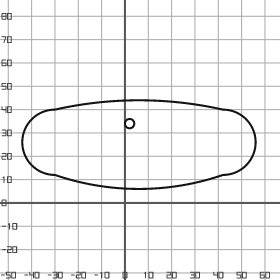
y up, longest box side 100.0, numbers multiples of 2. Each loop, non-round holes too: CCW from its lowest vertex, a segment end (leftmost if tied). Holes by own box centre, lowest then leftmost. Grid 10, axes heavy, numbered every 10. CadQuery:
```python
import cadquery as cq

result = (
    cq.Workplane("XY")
    .moveTo(-30.0, 12.0)
    .threePointArc((6.0, 6.0), (42.0, 12.0))
    .threePointArc((56.0, 26.0), (42.0, 40.0))
    .threePointArc((6.0, 44.0), (-30.0, 40.0))
    .threePointArc((-44.0, 26.0), (-30.0, 12.0))
    .close()
    .moveTo(2.0, 34.0)
    .circle(2.0)
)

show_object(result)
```